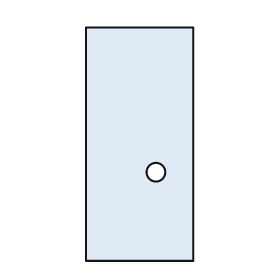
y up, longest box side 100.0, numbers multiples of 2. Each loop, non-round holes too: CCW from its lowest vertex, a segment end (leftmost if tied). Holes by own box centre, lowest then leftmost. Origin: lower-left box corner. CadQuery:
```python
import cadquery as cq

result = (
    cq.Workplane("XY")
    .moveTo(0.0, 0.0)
    .lineTo(46.0, 0.0)
    .lineTo(46.0, 100.0)
    .lineTo(0.0, 100.0)
    .close()
    .moveTo(30.0, 38.0)
    .circle(4.0)
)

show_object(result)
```